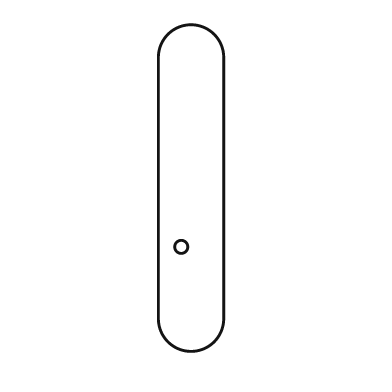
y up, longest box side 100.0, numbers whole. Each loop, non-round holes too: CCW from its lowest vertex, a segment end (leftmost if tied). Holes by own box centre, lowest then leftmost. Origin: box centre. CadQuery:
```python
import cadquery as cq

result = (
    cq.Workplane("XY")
    .moveTo(-10.0, -40.0)
    .threePointArc((0.0, -50.0), (10.0, -40.0))
    .lineTo(10.0, 40.0)
    .threePointArc((0.0, 50.0), (-10.0, 40.0))
    .close()
    .moveTo(-3.0, -18.0)
    .circle(2.0)
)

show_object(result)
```